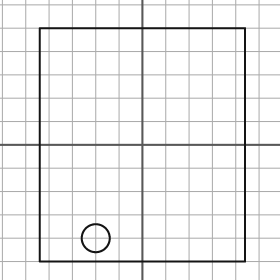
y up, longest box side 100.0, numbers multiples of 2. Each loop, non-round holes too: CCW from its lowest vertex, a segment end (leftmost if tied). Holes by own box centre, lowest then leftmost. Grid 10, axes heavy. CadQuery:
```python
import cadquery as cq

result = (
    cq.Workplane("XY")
    .moveTo(-44.0, -50.0)
    .lineTo(44.0, -50.0)
    .lineTo(44.0, 50.0)
    .lineTo(-44.0, 50.0)
    .close()
    .moveTo(-20.0, -40.0)
    .circle(6.0)
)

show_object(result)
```